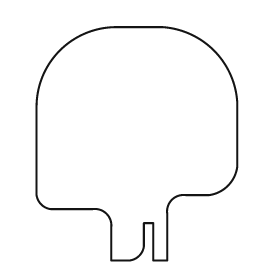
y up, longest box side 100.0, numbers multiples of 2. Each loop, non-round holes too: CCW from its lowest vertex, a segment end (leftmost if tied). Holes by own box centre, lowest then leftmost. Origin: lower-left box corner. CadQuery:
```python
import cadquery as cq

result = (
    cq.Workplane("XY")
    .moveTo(32.0, 0.0)
    .lineTo(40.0, 0.0)
    .threePointArc((44.0, 2.0), (46.0, 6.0))
    .lineTo(46.0, 16.0)
    .lineTo(50.0, 16.0)
    .lineTo(50.0, 0.0)
    .lineTo(56.0, 0.0)
    .lineTo(56.0, 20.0)
    .threePointArc((58.0, 26.0), (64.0, 28.0))
    .lineTo(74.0, 28.0)
    .threePointArc((82.0, 32.0), (86.0, 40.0))
    .lineTo(86.0, 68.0)
    .threePointArc((76.0, 90.0), (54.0, 100.0))
    .lineTo(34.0, 100.0)
    .threePointArc((10.0, 90.0), (0.0, 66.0))
    .lineTo(0.0, 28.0)
    .threePointArc((2.0, 24.0), (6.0, 22.0))
    .lineTo(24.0, 22.0)
    .threePointArc((30.0, 20.0), (32.0, 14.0))
    .close()
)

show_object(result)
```